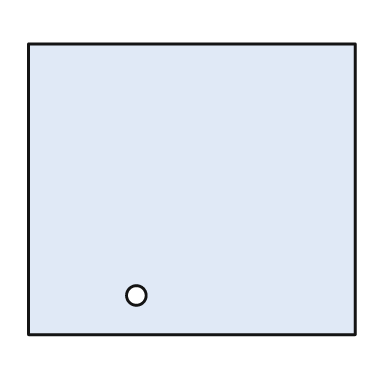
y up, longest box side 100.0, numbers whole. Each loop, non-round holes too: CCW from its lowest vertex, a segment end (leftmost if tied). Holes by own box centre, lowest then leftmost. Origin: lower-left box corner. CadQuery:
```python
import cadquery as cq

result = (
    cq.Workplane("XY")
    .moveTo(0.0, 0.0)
    .lineTo(100.0, 0.0)
    .lineTo(100.0, 89.0)
    .lineTo(0.0, 89.0)
    .close()
    .moveTo(33.0, 12.0)
    .circle(3.0)
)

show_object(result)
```